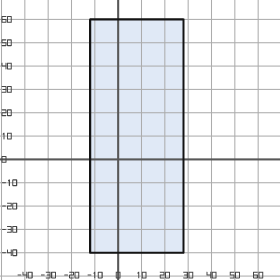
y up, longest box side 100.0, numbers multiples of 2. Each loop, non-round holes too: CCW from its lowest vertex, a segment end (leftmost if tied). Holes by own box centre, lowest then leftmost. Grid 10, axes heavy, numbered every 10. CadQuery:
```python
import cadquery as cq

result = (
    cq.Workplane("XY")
    .moveTo(-12.0, -40.0)
    .lineTo(28.0, -40.0)
    .lineTo(28.0, 60.0)
    .lineTo(-12.0, 60.0)
    .close()
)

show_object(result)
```